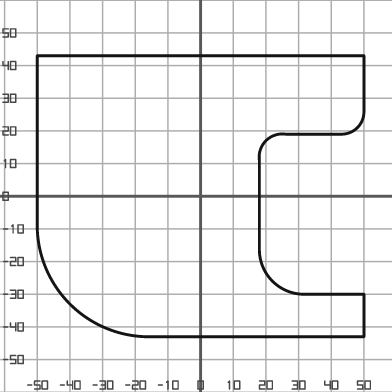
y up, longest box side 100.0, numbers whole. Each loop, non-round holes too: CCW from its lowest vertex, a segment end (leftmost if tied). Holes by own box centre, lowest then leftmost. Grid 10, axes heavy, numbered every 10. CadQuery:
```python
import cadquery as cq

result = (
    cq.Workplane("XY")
    .moveTo(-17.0, -43.0)
    .lineTo(50.0, -43.0)
    .lineTo(50.0, -30.0)
    .lineTo(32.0, -30.0)
    .threePointArc((22.0, -26.0), (18.0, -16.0))
    .lineTo(18.0, 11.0)
    .threePointArc((20.0, 17.0), (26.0, 19.0))
    .lineTo(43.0, 19.0)
    .threePointArc((48.0, 21.0), (50.0, 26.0))
    .lineTo(50.0, 43.0)
    .lineTo(-50.0, 43.0)
    .lineTo(-50.0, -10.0)
    .threePointArc((-40.0, -33.0), (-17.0, -43.0))
    .close()
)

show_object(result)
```